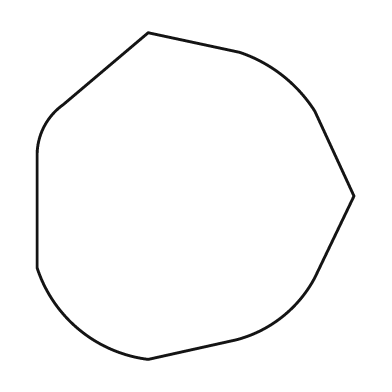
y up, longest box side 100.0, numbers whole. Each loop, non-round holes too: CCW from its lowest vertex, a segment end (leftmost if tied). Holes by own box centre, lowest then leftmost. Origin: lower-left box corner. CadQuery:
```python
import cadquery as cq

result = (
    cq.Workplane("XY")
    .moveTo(34.0, 0.0)
    .lineTo(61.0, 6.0)
    .threePointArc((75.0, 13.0), (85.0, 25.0))
    .lineTo(97.0, 50.0)
    .lineTo(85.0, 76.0)
    .threePointArc((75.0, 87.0), (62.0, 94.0))
    .lineTo(34.0, 100.0)
    .lineTo(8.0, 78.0)
    .threePointArc((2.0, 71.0), (0.0, 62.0))
    .lineTo(0.0, 28.0)
    .threePointArc((13.0, 9.0), (34.0, 0.0))
    .close()
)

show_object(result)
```